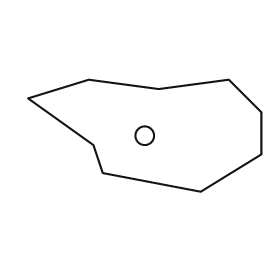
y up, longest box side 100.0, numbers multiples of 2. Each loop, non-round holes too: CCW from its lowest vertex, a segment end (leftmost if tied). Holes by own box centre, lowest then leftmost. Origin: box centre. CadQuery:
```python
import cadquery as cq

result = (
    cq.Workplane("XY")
    .moveTo(24.0, -24.0)
    .lineTo(50.0, -8.0)
    .lineTo(50.0, 10.0)
    .lineTo(36.0, 24.0)
    .lineTo(6.0, 20.0)
    .lineTo(-24.0, 24.0)
    .lineTo(-50.0, 16.0)
    .lineTo(-22.0, -4.0)
    .lineTo(-18.0, -16.0)
    .close()
    .moveTo(0.0, 0.0)
    .circle(4.0)
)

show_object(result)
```